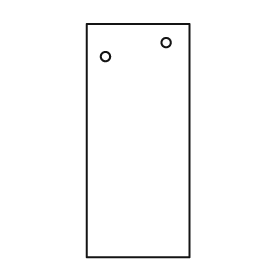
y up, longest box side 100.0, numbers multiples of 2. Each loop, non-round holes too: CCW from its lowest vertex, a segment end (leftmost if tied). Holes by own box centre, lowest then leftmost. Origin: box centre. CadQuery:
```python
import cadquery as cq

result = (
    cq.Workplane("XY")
    .moveTo(-22.0, -50.0)
    .lineTo(22.0, -50.0)
    .lineTo(22.0, 50.0)
    .lineTo(-22.0, 50.0)
    .close()
    .moveTo(-14.0, 36.0)
    .circle(2.0)
    .moveTo(12.0, 42.0)
    .circle(2.0)
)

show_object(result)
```